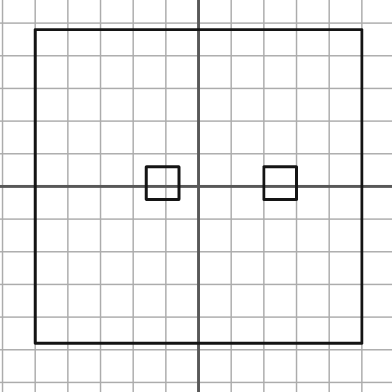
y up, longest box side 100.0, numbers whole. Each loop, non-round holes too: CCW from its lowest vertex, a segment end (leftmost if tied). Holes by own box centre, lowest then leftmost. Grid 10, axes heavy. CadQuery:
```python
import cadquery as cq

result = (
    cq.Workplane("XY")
    .moveTo(-50.0, -48.0)
    .lineTo(50.0, -48.0)
    .lineTo(50.0, 48.0)
    .lineTo(-50.0, 48.0)
    .close()
    .moveTo(-16.0, -4.0)
    .lineTo(-6.0, -4.0)
    .lineTo(-6.0, 6.0)
    .lineTo(-16.0, 6.0)
    .close()
    .moveTo(20.0, -4.0)
    .lineTo(30.0, -4.0)
    .lineTo(30.0, 6.0)
    .lineTo(20.0, 6.0)
    .close()
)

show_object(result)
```